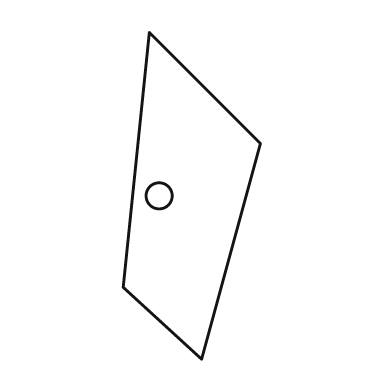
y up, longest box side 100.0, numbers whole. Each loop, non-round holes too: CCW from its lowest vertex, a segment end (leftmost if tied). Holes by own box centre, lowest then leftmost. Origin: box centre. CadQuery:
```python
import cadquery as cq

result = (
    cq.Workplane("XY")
    .moveTo(3.0, -50.0)
    .lineTo(21.0, 16.0)
    .lineTo(-13.0, 50.0)
    .lineTo(-21.0, -28.0)
    .close()
    .moveTo(-10.0, 0.0)
    .circle(4.0)
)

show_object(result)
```